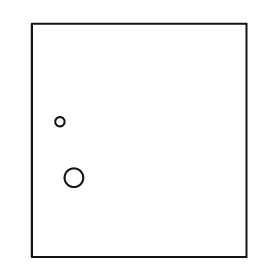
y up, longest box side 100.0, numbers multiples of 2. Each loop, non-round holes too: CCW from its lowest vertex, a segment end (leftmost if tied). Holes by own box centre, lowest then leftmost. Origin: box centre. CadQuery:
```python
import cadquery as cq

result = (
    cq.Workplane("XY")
    .moveTo(-46.0, -50.0)
    .lineTo(46.0, -50.0)
    .lineTo(46.0, 50.0)
    .lineTo(-46.0, 50.0)
    .close()
    .moveTo(-28.0, -16.0)
    .circle(4.0)
    .moveTo(-34.0, 8.0)
    .circle(2.0)
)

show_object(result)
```